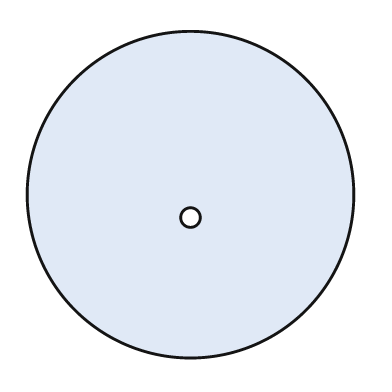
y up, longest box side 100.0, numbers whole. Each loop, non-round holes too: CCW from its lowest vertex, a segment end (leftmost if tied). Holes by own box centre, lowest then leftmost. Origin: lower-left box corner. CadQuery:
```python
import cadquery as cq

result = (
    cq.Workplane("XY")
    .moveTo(50.0, 50.0)
    .circle(50.0)
    .moveTo(50.0, 43.0)
    .circle(3.0)
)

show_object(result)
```